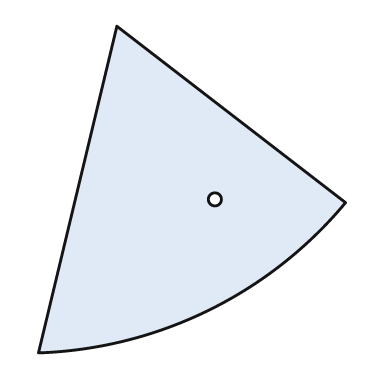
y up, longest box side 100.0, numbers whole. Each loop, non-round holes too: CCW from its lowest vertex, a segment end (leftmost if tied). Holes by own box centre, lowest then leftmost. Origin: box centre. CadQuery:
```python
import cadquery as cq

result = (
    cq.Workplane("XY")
    .moveTo(-47.0, -50.0)
    .threePointArc((5.0, -37.0), (47.0, -4.0))
    .lineTo(-23.0, 50.0)
    .close()
    .moveTo(7.0, -3.0)
    .circle(2.0)
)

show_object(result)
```